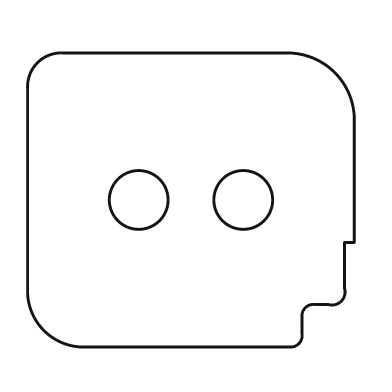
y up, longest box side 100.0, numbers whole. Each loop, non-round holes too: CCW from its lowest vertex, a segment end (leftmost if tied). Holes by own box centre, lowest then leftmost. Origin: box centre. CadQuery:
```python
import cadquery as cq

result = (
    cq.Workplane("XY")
    .moveTo(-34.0, -45.0)
    .lineTo(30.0, -45.0)
    .threePointArc((33.0, -44.0), (34.0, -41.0))
    .lineTo(34.0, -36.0)
    .threePointArc((35.0, -33.0), (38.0, -32.0))
    .lineTo(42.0, -32.0)
    .threePointArc((46.0, -31.0), (47.0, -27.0))
    .lineTo(47.0, -13.0)
    .lineTo(50.0, -13.0)
    .lineTo(50.0, 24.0)
    .threePointArc((44.0, 39.0), (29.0, 45.0))
    .lineTo(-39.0, 45.0)
    .threePointArc((-47.0, 42.0), (-50.0, 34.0))
    .lineTo(-50.0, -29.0)
    .threePointArc((-45.0, -40.0), (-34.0, -45.0))
    .close()
    .moveTo(-16.0, 0.0)
    .circle(9.0)
    .moveTo(16.0, 0.0)
    .circle(9.0)
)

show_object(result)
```